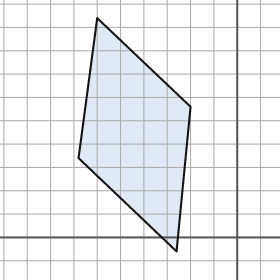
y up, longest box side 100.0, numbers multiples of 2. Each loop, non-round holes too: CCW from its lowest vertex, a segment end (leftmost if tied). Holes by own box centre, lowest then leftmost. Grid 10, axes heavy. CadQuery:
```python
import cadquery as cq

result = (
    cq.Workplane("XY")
    .moveTo(-26.0, -6.0)
    .lineTo(-20.0, 56.0)
    .lineTo(-60.0, 94.0)
    .lineTo(-68.0, 34.0)
    .close()
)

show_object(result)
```